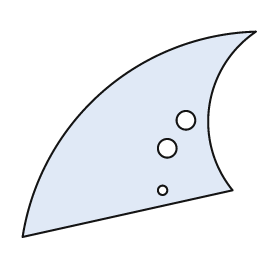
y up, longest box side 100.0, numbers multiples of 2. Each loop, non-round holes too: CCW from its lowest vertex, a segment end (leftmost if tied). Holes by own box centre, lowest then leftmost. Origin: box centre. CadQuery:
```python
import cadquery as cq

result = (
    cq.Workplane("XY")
    .moveTo(-50.0, -44.0)
    .lineTo(40.0, -24.0)
    .threePointArc((30.0, 12.0), (50.0, 44.0))
    .threePointArc((-16.0, 18.0), (-50.0, -44.0))
    .close()
    .moveTo(10.0, -24.0)
    .circle(2.0)
    .moveTo(12.0, -6.0)
    .circle(4.0)
    .moveTo(20.0, 6.0)
    .circle(4.0)
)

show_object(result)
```